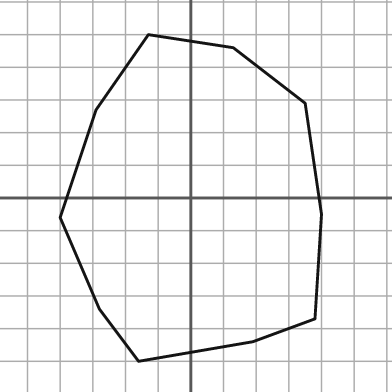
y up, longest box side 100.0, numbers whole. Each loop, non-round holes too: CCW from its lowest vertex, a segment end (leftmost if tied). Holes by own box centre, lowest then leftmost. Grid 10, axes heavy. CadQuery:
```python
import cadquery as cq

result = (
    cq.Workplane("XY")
    .moveTo(-16.0, -50.0)
    .lineTo(19.0, -44.0)
    .lineTo(38.0, -37.0)
    .lineTo(40.0, -5.0)
    .lineTo(35.0, 29.0)
    .lineTo(13.0, 46.0)
    .lineTo(-13.0, 50.0)
    .lineTo(-29.0, 27.0)
    .lineTo(-40.0, -6.0)
    .lineTo(-28.0, -34.0)
    .close()
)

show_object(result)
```